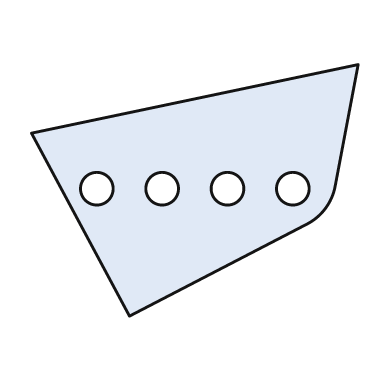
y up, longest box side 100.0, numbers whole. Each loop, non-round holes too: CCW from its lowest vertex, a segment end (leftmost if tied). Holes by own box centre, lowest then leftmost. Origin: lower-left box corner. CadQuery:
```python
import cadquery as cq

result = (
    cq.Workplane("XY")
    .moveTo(30.0, 0.0)
    .lineTo(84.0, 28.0)
    .threePointArc((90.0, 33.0), (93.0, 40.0))
    .lineTo(100.0, 77.0)
    .lineTo(0.0, 56.0)
    .close()
    .moveTo(20.0, 39.0)
    .circle(5.0)
    .moveTo(40.0, 39.0)
    .circle(5.0)
    .moveTo(60.0, 39.0)
    .circle(5.0)
    .moveTo(80.0, 39.0)
    .circle(5.0)
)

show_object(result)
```